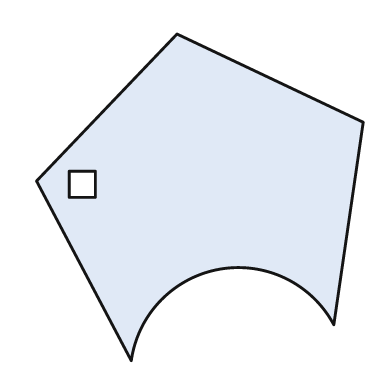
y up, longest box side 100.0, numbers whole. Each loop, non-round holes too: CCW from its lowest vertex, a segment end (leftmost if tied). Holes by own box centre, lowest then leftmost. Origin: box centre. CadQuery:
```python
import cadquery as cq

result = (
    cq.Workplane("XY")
    .moveTo(-21.0, -50.0)
    .threePointArc((6.0, -22.0), (41.0, -39.0))
    .lineTo(50.0, 23.0)
    .lineTo(-7.0, 50.0)
    .lineTo(-50.0, 5.0)
    .close()
    .moveTo(-40.0, 0.0)
    .lineTo(-32.0, 0.0)
    .lineTo(-32.0, 8.0)
    .lineTo(-40.0, 8.0)
    .close()
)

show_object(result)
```